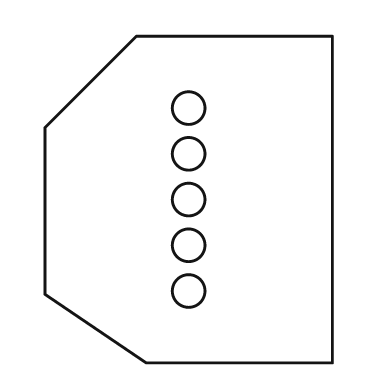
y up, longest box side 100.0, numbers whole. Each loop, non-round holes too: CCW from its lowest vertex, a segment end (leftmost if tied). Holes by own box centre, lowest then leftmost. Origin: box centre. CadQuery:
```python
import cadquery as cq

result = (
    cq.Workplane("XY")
    .moveTo(-13.0, -50.0)
    .lineTo(44.0, -50.0)
    .lineTo(44.0, 50.0)
    .lineTo(-16.0, 50.0)
    .lineTo(-44.0, 22.0)
    .lineTo(-44.0, -29.0)
    .close()
    .moveTo(0.0, -28.0)
    .circle(5.0)
    .moveTo(0.0, -14.0)
    .circle(5.0)
    .moveTo(0.0, 0.0)
    .circle(5.0)
    .moveTo(0.0, 14.0)
    .circle(5.0)
    .moveTo(0.0, 28.0)
    .circle(5.0)
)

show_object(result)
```